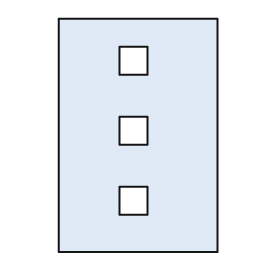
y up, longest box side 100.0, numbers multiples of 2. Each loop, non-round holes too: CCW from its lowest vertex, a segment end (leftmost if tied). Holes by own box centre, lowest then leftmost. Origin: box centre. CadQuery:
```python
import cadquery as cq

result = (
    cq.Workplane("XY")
    .moveTo(-34.0, -50.0)
    .lineTo(34.0, -50.0)
    .lineTo(34.0, 50.0)
    .lineTo(-34.0, 50.0)
    .close()
    .moveTo(-8.0, -34.0)
    .lineTo(4.0, -34.0)
    .lineTo(4.0, -22.0)
    .lineTo(-8.0, -22.0)
    .close()
    .moveTo(-8.0, -4.0)
    .lineTo(4.0, -4.0)
    .lineTo(4.0, 8.0)
    .lineTo(-8.0, 8.0)
    .close()
    .moveTo(-8.0, 26.0)
    .lineTo(4.0, 26.0)
    .lineTo(4.0, 38.0)
    .lineTo(-8.0, 38.0)
    .close()
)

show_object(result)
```